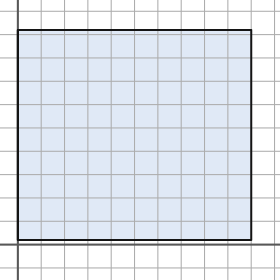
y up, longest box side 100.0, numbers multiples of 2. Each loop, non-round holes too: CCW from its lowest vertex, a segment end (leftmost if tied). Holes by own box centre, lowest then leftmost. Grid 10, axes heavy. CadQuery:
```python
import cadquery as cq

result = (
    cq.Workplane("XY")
    .moveTo(0.0, 2.0)
    .lineTo(100.0, 2.0)
    .lineTo(100.0, 92.0)
    .lineTo(0.0, 92.0)
    .close()
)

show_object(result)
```